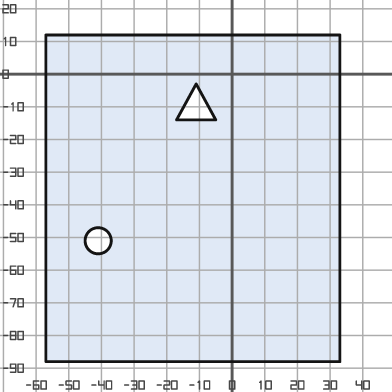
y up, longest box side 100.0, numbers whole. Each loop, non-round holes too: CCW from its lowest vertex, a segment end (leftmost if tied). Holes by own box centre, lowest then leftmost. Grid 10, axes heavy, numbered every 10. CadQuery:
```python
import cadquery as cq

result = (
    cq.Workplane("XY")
    .moveTo(-57.0, -88.0)
    .lineTo(33.0, -88.0)
    .lineTo(33.0, 12.0)
    .lineTo(-57.0, 12.0)
    .close()
    .moveTo(-41.0, -51.0)
    .circle(4.0)
    .moveTo(-17.0, -14.0)
    .lineTo(-5.0, -14.0)
    .lineTo(-11.0, -3.0)
    .close()
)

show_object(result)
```